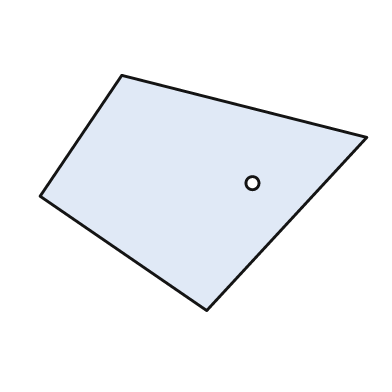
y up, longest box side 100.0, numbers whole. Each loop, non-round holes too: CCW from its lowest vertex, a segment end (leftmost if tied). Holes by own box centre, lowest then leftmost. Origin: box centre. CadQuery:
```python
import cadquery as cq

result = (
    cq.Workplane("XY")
    .moveTo(1.0, -36.0)
    .lineTo(50.0, 17.0)
    .lineTo(-25.0, 36.0)
    .lineTo(-50.0, -1.0)
    .close()
    .moveTo(15.0, 3.0)
    .circle(2.0)
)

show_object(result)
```